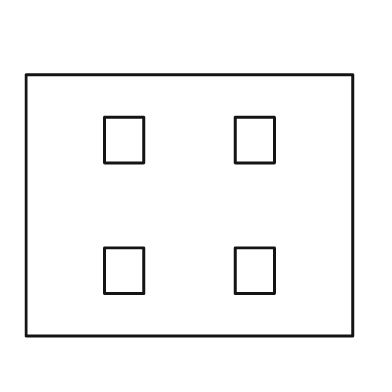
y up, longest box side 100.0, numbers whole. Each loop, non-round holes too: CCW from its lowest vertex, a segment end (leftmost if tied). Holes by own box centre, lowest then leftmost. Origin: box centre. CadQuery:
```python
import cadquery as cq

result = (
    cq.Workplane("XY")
    .moveTo(-50.0, -40.0)
    .lineTo(50.0, -40.0)
    .lineTo(50.0, 40.0)
    .lineTo(-50.0, 40.0)
    .close()
    .moveTo(-26.0, -27.0)
    .lineTo(-14.0, -27.0)
    .lineTo(-14.0, -13.0)
    .lineTo(-26.0, -13.0)
    .close()
    .moveTo(14.0, -27.0)
    .lineTo(26.0, -27.0)
    .lineTo(26.0, -13.0)
    .lineTo(14.0, -13.0)
    .close()
    .moveTo(-26.0, 13.0)
    .lineTo(-14.0, 13.0)
    .lineTo(-14.0, 27.0)
    .lineTo(-26.0, 27.0)
    .close()
    .moveTo(14.0, 13.0)
    .lineTo(26.0, 13.0)
    .lineTo(26.0, 27.0)
    .lineTo(14.0, 27.0)
    .close()
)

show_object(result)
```